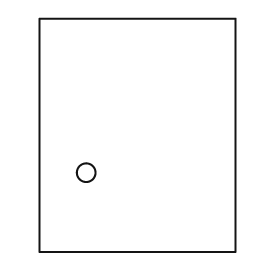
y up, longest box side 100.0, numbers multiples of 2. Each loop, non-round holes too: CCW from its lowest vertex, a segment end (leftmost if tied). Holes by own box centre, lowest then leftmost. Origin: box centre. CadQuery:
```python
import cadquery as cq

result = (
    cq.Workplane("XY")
    .moveTo(-42.0, -50.0)
    .lineTo(42.0, -50.0)
    .lineTo(42.0, 50.0)
    .lineTo(-42.0, 50.0)
    .close()
    .moveTo(-22.0, -16.0)
    .circle(4.0)
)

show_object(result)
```